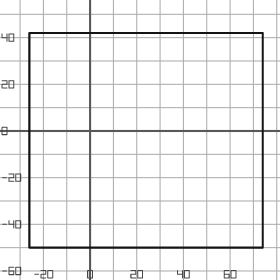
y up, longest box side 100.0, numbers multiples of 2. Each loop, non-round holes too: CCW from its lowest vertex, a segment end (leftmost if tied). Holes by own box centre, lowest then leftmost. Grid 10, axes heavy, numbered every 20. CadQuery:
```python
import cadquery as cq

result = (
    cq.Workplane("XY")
    .moveTo(-26.0, -50.0)
    .lineTo(74.0, -50.0)
    .lineTo(74.0, 42.0)
    .lineTo(-26.0, 42.0)
    .close()
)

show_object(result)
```